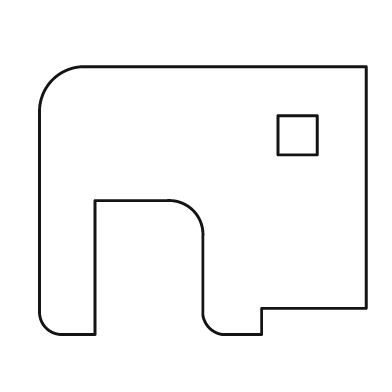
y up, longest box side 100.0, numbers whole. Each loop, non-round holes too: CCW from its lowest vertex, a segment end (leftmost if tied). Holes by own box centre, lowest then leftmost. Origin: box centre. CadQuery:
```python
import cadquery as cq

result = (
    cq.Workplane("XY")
    .moveTo(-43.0, -41.0)
    .lineTo(-33.0, -41.0)
    .lineTo(-33.0, 0.0)
    .lineTo(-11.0, 0.0)
    .threePointArc((-3.0, -3.0), (0.0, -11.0))
    .lineTo(0.0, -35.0)
    .threePointArc((2.0, -39.0), (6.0, -41.0))
    .lineTo(18.0, -41.0)
    .lineTo(18.0, -33.0)
    .lineTo(50.0, -33.0)
    .lineTo(50.0, 41.0)
    .lineTo(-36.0, 41.0)
    .threePointArc((-46.0, 37.0), (-50.0, 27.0))
    .lineTo(-50.0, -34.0)
    .threePointArc((-48.0, -39.0), (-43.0, -41.0))
    .close()
    .moveTo(23.0, 14.0)
    .lineTo(35.0, 14.0)
    .lineTo(35.0, 26.0)
    .lineTo(23.0, 26.0)
    .close()
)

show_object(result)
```